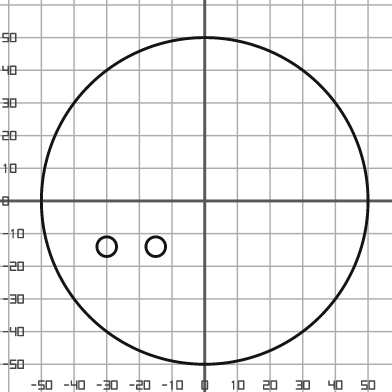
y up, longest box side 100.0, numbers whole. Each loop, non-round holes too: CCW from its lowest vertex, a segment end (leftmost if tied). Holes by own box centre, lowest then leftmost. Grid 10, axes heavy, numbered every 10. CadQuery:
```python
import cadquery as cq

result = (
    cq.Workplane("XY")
    .moveTo(0.0, 0.0)
    .circle(50.0)
    .moveTo(-30.0, -14.0)
    .circle(3.0)
    .moveTo(-15.0, -14.0)
    .circle(3.0)
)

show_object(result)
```